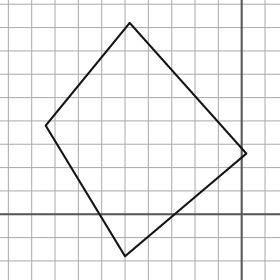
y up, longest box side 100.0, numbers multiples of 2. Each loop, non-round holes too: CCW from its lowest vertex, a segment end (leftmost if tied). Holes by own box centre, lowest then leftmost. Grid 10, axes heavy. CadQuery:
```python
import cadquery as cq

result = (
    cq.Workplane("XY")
    .moveTo(-50.0, -18.0)
    .lineTo(2.0, 26.0)
    .lineTo(-48.0, 82.0)
    .lineTo(-84.0, 38.0)
    .close()
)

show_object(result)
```